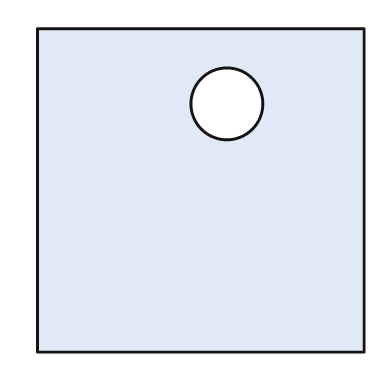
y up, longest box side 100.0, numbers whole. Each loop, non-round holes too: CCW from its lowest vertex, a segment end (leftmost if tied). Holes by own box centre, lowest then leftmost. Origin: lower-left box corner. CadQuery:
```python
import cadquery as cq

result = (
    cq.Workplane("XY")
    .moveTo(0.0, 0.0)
    .lineTo(100.0, 0.0)
    .lineTo(100.0, 99.0)
    .lineTo(0.0, 99.0)
    .close()
    .moveTo(58.0, 76.0)
    .circle(11.0)
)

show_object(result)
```